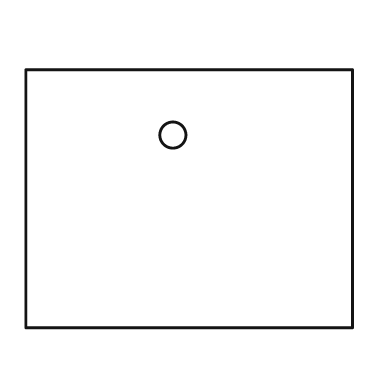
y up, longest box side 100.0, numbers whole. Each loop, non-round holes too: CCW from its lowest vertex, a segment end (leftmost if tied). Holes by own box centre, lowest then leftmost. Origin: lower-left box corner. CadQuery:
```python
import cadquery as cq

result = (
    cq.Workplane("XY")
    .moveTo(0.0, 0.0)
    .lineTo(100.0, 0.0)
    .lineTo(100.0, 79.0)
    .lineTo(0.0, 79.0)
    .close()
    .moveTo(45.0, 59.0)
    .circle(4.0)
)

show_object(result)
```